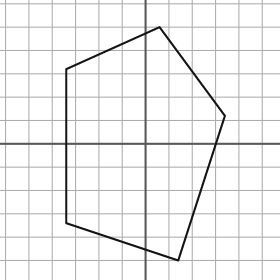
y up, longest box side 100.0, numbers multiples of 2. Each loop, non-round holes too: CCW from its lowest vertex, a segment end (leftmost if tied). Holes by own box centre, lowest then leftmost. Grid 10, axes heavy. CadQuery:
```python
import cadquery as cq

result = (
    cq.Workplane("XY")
    .moveTo(14.0, -50.0)
    .lineTo(34.0, 12.0)
    .lineTo(6.0, 50.0)
    .lineTo(-34.0, 32.0)
    .lineTo(-34.0, -34.0)
    .close()
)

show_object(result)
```